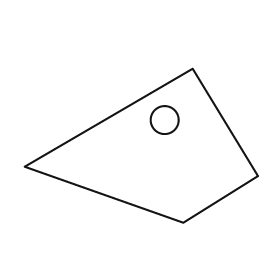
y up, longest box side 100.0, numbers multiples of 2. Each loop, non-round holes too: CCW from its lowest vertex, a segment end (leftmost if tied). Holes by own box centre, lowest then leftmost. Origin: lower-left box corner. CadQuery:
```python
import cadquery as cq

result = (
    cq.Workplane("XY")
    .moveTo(68.0, 0.0)
    .lineTo(100.0, 20.0)
    .lineTo(72.0, 66.0)
    .lineTo(0.0, 24.0)
    .close()
    .moveTo(60.0, 44.0)
    .circle(6.0)
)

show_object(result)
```